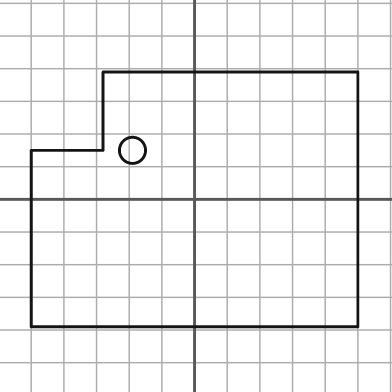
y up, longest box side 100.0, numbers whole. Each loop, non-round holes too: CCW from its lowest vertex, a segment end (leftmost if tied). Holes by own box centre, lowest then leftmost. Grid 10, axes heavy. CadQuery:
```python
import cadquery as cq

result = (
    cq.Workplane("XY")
    .moveTo(-50.0, -39.0)
    .lineTo(50.0, -39.0)
    .lineTo(50.0, 39.0)
    .lineTo(-28.0, 39.0)
    .lineTo(-28.0, 15.0)
    .lineTo(-50.0, 15.0)
    .close()
    .moveTo(-19.0, 15.0)
    .circle(4.0)
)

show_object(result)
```